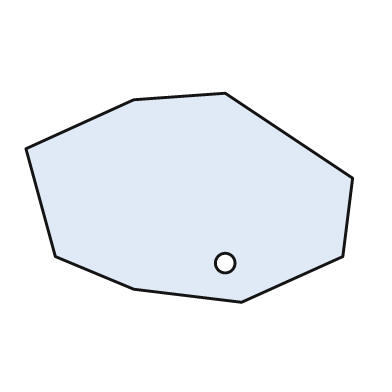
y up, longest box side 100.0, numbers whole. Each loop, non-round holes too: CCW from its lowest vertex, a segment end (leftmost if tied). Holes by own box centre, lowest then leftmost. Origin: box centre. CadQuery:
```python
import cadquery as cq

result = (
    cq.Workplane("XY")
    .moveTo(16.0, -32.0)
    .lineTo(47.0, -18.0)
    .lineTo(50.0, 6.0)
    .lineTo(11.0, 32.0)
    .lineTo(-17.0, 30.0)
    .lineTo(-50.0, 15.0)
    .lineTo(-41.0, -18.0)
    .lineTo(-17.0, -28.0)
    .close()
    .moveTo(11.0, -20.0)
    .circle(3.0)
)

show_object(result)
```